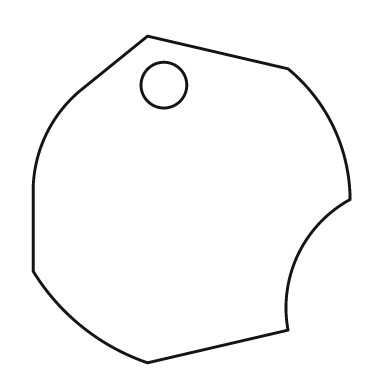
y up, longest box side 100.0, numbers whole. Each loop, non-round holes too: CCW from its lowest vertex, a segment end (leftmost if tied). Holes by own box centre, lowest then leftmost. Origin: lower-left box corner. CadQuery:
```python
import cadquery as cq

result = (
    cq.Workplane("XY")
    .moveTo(35.0, 0.0)
    .lineTo(78.0, 10.0)
    .threePointArc((81.0, 33.0), (97.0, 50.0))
    .threePointArc((92.0, 72.0), (78.0, 90.0))
    .lineTo(35.0, 100.0)
    .lineTo(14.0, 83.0)
    .threePointArc((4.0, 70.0), (0.0, 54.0))
    .lineTo(0.0, 28.0)
    .threePointArc((15.0, 11.0), (35.0, 0.0))
    .close()
    .moveTo(40.0, 85.0)
    .circle(7.0)
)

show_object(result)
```